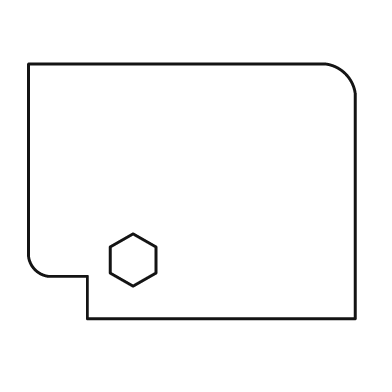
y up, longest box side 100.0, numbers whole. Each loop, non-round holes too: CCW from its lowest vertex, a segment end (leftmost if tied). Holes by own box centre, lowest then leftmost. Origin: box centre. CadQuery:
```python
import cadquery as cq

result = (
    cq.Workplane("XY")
    .moveTo(-32.0, -39.0)
    .lineTo(50.0, -39.0)
    .lineTo(50.0, 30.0)
    .threePointArc((47.0, 36.0), (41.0, 39.0))
    .lineTo(-50.0, 39.0)
    .lineTo(-50.0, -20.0)
    .threePointArc((-48.0, -24.0), (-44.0, -26.0))
    .lineTo(-32.0, -26.0)
    .close()
    .moveTo(-18.0, -29.0)
    .lineTo(-11.0, -25.0)
    .lineTo(-11.0, -17.0)
    .lineTo(-18.0, -13.0)
    .lineTo(-25.0, -17.0)
    .lineTo(-25.0, -25.0)
    .close()
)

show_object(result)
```